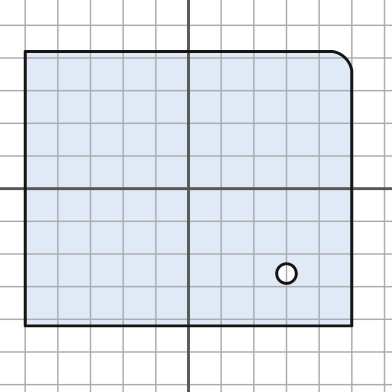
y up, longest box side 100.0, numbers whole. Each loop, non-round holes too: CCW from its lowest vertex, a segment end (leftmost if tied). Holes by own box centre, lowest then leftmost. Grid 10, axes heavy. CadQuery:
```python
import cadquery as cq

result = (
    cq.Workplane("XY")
    .moveTo(-50.0, -42.0)
    .lineTo(50.0, -42.0)
    .lineTo(50.0, 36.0)
    .threePointArc((48.0, 40.0), (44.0, 42.0))
    .lineTo(-50.0, 42.0)
    .close()
    .moveTo(30.0, -26.0)
    .circle(3.0)
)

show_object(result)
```